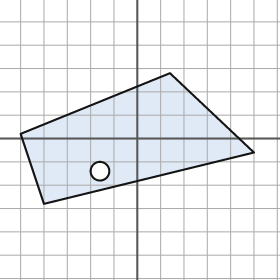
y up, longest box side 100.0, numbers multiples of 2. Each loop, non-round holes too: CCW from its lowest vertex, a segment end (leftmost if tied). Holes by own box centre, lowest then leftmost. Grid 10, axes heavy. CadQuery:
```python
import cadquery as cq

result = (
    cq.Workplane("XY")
    .moveTo(-40.0, -28.0)
    .lineTo(50.0, -6.0)
    .lineTo(14.0, 28.0)
    .lineTo(-50.0, 2.0)
    .close()
    .moveTo(-16.0, -14.0)
    .circle(4.0)
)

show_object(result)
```